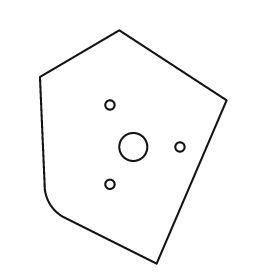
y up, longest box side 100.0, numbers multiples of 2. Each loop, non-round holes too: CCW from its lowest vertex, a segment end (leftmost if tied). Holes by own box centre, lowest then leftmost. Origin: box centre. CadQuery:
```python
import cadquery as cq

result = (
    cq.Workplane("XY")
    .moveTo(10.0, -50.0)
    .lineTo(40.0, 20.0)
    .lineTo(-6.0, 50.0)
    .lineTo(-40.0, 30.0)
    .lineTo(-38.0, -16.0)
    .threePointArc((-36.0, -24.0), (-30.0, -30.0))
    .close()
    .moveTo(-10.0, -16.0)
    .circle(2.0)
    .moveTo(0.0, 0.0)
    .circle(6.0)
    .moveTo(20.0, 0.0)
    .circle(2.0)
    .moveTo(-10.0, 18.0)
    .circle(2.0)
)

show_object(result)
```